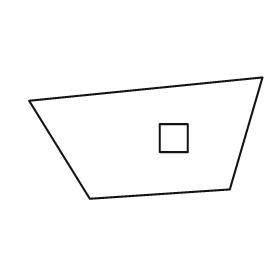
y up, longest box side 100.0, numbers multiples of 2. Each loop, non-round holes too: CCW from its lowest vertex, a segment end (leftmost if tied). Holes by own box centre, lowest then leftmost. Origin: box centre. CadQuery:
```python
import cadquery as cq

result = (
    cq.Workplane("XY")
    .moveTo(-24.0, -26.0)
    .lineTo(36.0, -22.0)
    .lineTo(50.0, 26.0)
    .lineTo(-50.0, 16.0)
    .close()
    .moveTo(6.0, -6.0)
    .lineTo(18.0, -6.0)
    .lineTo(18.0, 6.0)
    .lineTo(6.0, 6.0)
    .close()
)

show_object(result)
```